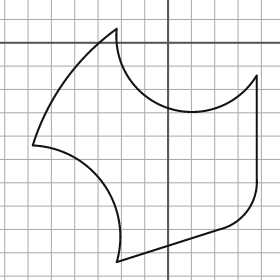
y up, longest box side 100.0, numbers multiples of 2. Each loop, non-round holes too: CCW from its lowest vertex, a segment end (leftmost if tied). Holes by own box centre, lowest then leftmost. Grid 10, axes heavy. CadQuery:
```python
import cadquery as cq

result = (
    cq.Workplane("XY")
    .moveTo(-22.0, -94.0)
    .lineTo(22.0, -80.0)
    .threePointArc((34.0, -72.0), (38.0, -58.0))
    .lineTo(38.0, -14.0)
    .threePointArc((0.0, -28.0), (-22.0, 6.0))
    .threePointArc((-44.0, -16.0), (-58.0, -44.0))
    .threePointArc((-28.0, -60.0), (-22.0, -94.0))
    .close()
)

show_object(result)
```